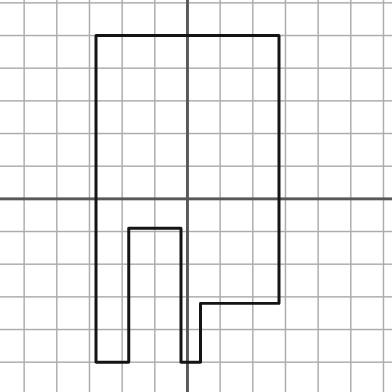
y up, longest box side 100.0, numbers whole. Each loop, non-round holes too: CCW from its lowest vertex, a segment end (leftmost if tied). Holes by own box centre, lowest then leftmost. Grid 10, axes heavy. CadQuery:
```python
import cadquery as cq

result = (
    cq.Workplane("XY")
    .moveTo(-28.0, -50.0)
    .lineTo(-18.0, -50.0)
    .lineTo(-18.0, -9.0)
    .lineTo(-2.0, -9.0)
    .lineTo(-2.0, -50.0)
    .lineTo(4.0, -50.0)
    .lineTo(4.0, -32.0)
    .lineTo(28.0, -32.0)
    .lineTo(28.0, 50.0)
    .lineTo(-28.0, 50.0)
    .close()
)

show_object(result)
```